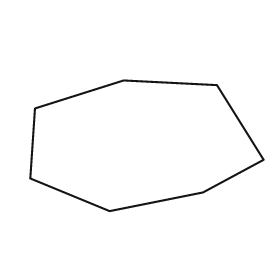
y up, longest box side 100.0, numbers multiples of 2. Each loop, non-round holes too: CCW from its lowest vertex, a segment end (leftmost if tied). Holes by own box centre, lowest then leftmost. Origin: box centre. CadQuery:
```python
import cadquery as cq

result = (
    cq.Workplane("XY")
    .moveTo(-16.0, -28.0)
    .lineTo(24.0, -20.0)
    .lineTo(50.0, -6.0)
    .lineTo(30.0, 26.0)
    .lineTo(-10.0, 28.0)
    .lineTo(-48.0, 16.0)
    .lineTo(-50.0, -14.0)
    .close()
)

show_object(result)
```